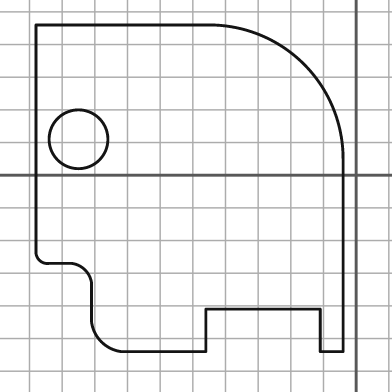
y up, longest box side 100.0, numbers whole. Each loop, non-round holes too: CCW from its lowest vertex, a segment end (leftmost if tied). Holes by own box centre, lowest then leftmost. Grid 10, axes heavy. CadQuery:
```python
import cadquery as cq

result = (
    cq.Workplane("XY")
    .moveTo(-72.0, -54.0)
    .lineTo(-46.0, -54.0)
    .lineTo(-46.0, -41.0)
    .lineTo(-11.0, -41.0)
    .lineTo(-11.0, -54.0)
    .lineTo(-4.0, -54.0)
    .lineTo(-4.0, 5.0)
    .threePointArc((-16.0, 34.0), (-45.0, 46.0))
    .lineTo(-98.0, 46.0)
    .lineTo(-98.0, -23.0)
    .threePointArc((-97.0, -26.0), (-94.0, -27.0))
    .lineTo(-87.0, -27.0)
    .threePointArc((-83.0, -29.0), (-81.0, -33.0))
    .lineTo(-81.0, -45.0)
    .threePointArc((-78.0, -51.0), (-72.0, -54.0))
    .close()
    .moveTo(-85.0, 11.0)
    .circle(9.0)
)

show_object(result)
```